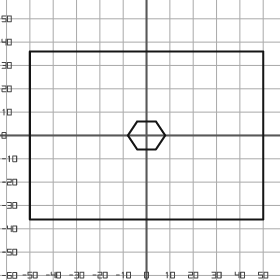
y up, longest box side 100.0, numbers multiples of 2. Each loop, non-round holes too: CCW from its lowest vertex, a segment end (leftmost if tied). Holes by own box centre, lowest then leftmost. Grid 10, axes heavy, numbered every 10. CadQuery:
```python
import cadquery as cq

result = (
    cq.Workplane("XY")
    .moveTo(-50.0, -36.0)
    .lineTo(50.0, -36.0)
    .lineTo(50.0, 36.0)
    .lineTo(-50.0, 36.0)
    .close()
    .moveTo(-4.0, -6.0)
    .lineTo(4.0, -6.0)
    .lineTo(8.0, 0.0)
    .lineTo(4.0, 6.0)
    .lineTo(-4.0, 6.0)
    .lineTo(-8.0, 0.0)
    .close()
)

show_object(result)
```